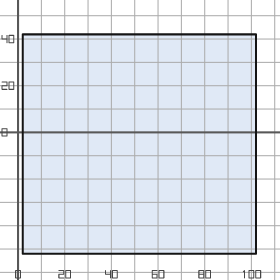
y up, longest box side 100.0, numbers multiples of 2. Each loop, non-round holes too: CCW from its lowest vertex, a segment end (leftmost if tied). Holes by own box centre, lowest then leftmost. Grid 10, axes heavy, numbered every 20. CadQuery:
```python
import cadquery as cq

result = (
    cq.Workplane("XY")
    .moveTo(2.0, -52.0)
    .lineTo(102.0, -52.0)
    .lineTo(102.0, 42.0)
    .lineTo(2.0, 42.0)
    .close()
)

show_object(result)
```